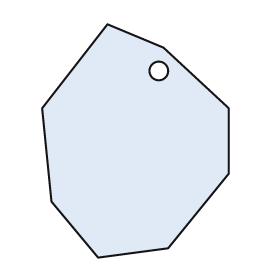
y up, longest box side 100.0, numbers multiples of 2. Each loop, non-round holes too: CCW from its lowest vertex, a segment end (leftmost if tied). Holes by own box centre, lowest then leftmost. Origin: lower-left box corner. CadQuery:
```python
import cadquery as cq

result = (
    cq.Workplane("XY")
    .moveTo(24.0, 0.0)
    .lineTo(54.0, 4.0)
    .lineTo(80.0, 36.0)
    .lineTo(80.0, 64.0)
    .lineTo(52.0, 90.0)
    .lineTo(28.0, 100.0)
    .lineTo(0.0, 64.0)
    .lineTo(4.0, 24.0)
    .close()
    .moveTo(50.0, 80.0)
    .circle(4.0)
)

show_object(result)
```